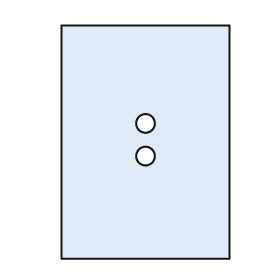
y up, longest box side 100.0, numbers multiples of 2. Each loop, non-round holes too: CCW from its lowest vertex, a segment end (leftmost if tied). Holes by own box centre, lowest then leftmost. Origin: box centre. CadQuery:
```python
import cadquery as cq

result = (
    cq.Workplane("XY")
    .moveTo(-36.0, -50.0)
    .lineTo(36.0, -50.0)
    .lineTo(36.0, 50.0)
    .lineTo(-36.0, 50.0)
    .close()
    .moveTo(0.0, -6.0)
    .circle(4.0)
    .moveTo(0.0, 8.0)
    .circle(4.0)
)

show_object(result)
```